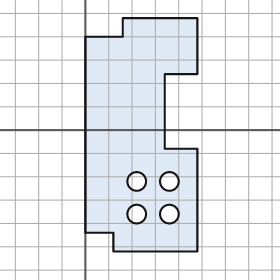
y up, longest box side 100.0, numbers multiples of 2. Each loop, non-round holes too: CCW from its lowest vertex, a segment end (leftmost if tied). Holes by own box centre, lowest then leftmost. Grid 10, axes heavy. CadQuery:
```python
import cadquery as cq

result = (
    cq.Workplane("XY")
    .moveTo(12.0, -52.0)
    .lineTo(48.0, -52.0)
    .lineTo(48.0, -8.0)
    .lineTo(34.0, -8.0)
    .lineTo(34.0, 24.0)
    .lineTo(48.0, 24.0)
    .lineTo(48.0, 48.0)
    .lineTo(16.0, 48.0)
    .lineTo(16.0, 40.0)
    .lineTo(0.0, 40.0)
    .lineTo(0.0, -44.0)
    .lineTo(12.0, -44.0)
    .close()
    .moveTo(22.0, -36.0)
    .circle(4.0)
    .moveTo(36.0, -36.0)
    .circle(4.0)
    .moveTo(22.0, -22.0)
    .circle(4.0)
    .moveTo(36.0, -22.0)
    .circle(4.0)
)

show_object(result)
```